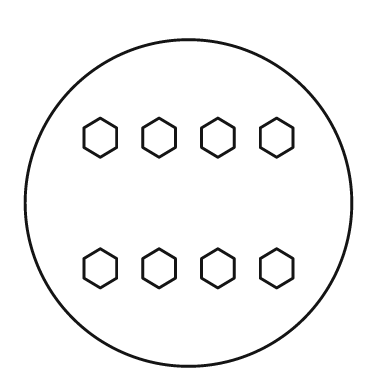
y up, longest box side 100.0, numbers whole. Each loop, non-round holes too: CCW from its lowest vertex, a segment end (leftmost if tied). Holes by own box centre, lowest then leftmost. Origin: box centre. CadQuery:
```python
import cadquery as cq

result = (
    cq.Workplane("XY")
    .moveTo(0.0, 0.0)
    .circle(50.0)
    .moveTo(-27.0, -26.0)
    .lineTo(-22.0, -23.0)
    .lineTo(-22.0, -17.0)
    .lineTo(-27.0, -14.0)
    .lineTo(-32.0, -17.0)
    .lineTo(-32.0, -23.0)
    .close()
    .moveTo(-9.0, -26.0)
    .lineTo(-4.0, -23.0)
    .lineTo(-4.0, -17.0)
    .lineTo(-9.0, -14.0)
    .lineTo(-14.0, -17.0)
    .lineTo(-14.0, -23.0)
    .close()
    .moveTo(9.0, -26.0)
    .lineTo(14.0, -23.0)
    .lineTo(14.0, -17.0)
    .lineTo(9.0, -14.0)
    .lineTo(4.0, -17.0)
    .lineTo(4.0, -23.0)
    .close()
    .moveTo(27.0, -26.0)
    .lineTo(32.0, -23.0)
    .lineTo(32.0, -17.0)
    .lineTo(27.0, -14.0)
    .lineTo(22.0, -17.0)
    .lineTo(22.0, -23.0)
    .close()
    .moveTo(-27.0, 14.0)
    .lineTo(-22.0, 17.0)
    .lineTo(-22.0, 23.0)
    .lineTo(-27.0, 26.0)
    .lineTo(-32.0, 23.0)
    .lineTo(-32.0, 17.0)
    .close()
    .moveTo(-9.0, 14.0)
    .lineTo(-4.0, 17.0)
    .lineTo(-4.0, 23.0)
    .lineTo(-9.0, 26.0)
    .lineTo(-14.0, 23.0)
    .lineTo(-14.0, 17.0)
    .close()
    .moveTo(9.0, 14.0)
    .lineTo(14.0, 17.0)
    .lineTo(14.0, 23.0)
    .lineTo(9.0, 26.0)
    .lineTo(4.0, 23.0)
    .lineTo(4.0, 17.0)
    .close()
    .moveTo(27.0, 14.0)
    .lineTo(32.0, 17.0)
    .lineTo(32.0, 23.0)
    .lineTo(27.0, 26.0)
    .lineTo(22.0, 23.0)
    .lineTo(22.0, 17.0)
    .close()
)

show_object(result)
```